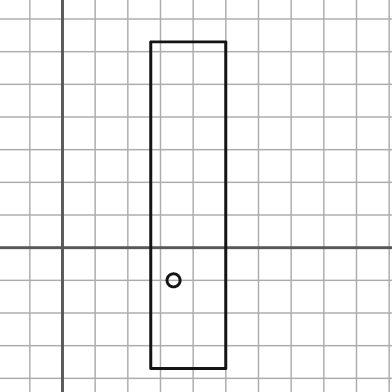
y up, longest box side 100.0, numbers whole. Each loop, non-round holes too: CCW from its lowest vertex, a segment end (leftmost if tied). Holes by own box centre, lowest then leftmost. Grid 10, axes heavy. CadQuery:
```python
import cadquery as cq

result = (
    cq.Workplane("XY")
    .moveTo(27.0, -37.0)
    .lineTo(50.0, -37.0)
    .lineTo(50.0, 63.0)
    .lineTo(27.0, 63.0)
    .close()
    .moveTo(34.0, -10.0)
    .circle(2.0)
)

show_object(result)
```